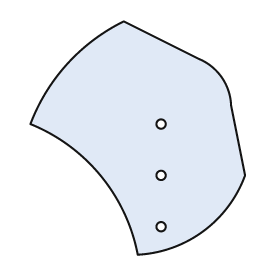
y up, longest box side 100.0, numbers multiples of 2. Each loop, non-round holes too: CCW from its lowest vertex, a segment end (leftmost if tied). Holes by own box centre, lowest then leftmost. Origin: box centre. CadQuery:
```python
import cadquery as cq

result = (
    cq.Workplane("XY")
    .moveTo(0.0, -50.0)
    .threePointArc((28.0, -40.0), (46.0, -16.0))
    .lineTo(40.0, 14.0)
    .threePointArc((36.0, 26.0), (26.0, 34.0))
    .lineTo(-6.0, 50.0)
    .threePointArc((-30.0, 32.0), (-46.0, 6.0))
    .threePointArc((-16.0, -16.0), (0.0, -50.0))
    .close()
    .moveTo(10.0, -38.0)
    .circle(2.0)
    .moveTo(10.0, -16.0)
    .circle(2.0)
    .moveTo(10.0, 6.0)
    .circle(2.0)
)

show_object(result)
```